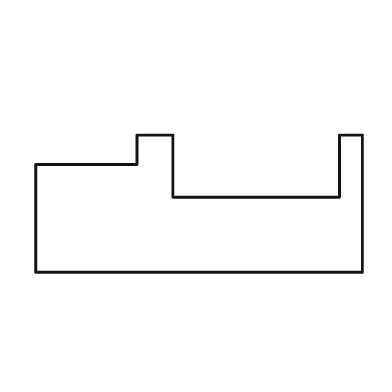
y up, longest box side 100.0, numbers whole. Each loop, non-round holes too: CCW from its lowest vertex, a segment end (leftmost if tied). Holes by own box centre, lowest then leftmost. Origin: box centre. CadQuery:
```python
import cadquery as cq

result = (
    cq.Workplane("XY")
    .moveTo(-50.0, -21.0)
    .lineTo(50.0, -21.0)
    .lineTo(50.0, 21.0)
    .lineTo(43.0, 21.0)
    .lineTo(43.0, 2.0)
    .lineTo(-8.0, 2.0)
    .lineTo(-8.0, 21.0)
    .lineTo(-19.0, 21.0)
    .lineTo(-19.0, 12.0)
    .lineTo(-50.0, 12.0)
    .close()
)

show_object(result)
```